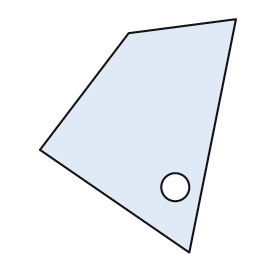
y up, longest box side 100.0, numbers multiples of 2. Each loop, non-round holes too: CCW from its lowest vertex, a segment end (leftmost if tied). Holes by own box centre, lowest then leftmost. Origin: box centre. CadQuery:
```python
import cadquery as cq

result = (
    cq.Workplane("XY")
    .moveTo(22.0, -50.0)
    .lineTo(42.0, 50.0)
    .lineTo(-4.0, 44.0)
    .lineTo(-42.0, -6.0)
    .close()
    .moveTo(16.0, -22.0)
    .circle(6.0)
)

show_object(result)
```